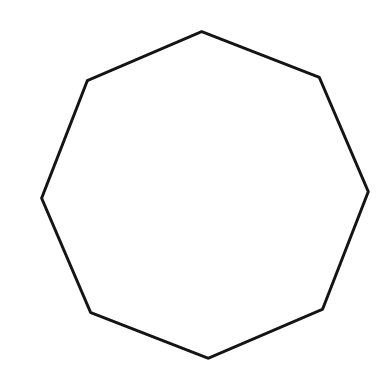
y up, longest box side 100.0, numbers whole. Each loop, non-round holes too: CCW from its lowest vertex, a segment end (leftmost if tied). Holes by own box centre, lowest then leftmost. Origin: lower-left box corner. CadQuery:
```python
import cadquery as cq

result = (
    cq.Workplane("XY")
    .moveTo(51.0, 0.0)
    .lineTo(86.0, 15.0)
    .lineTo(100.0, 51.0)
    .lineTo(85.0, 86.0)
    .lineTo(49.0, 100.0)
    .lineTo(14.0, 85.0)
    .lineTo(0.0, 49.0)
    .lineTo(15.0, 14.0)
    .close()
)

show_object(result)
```